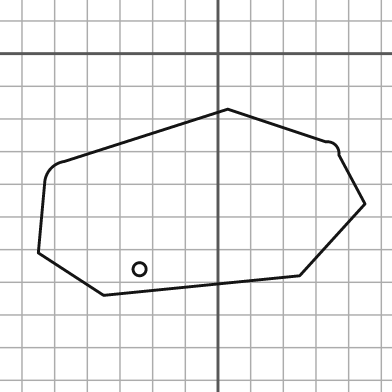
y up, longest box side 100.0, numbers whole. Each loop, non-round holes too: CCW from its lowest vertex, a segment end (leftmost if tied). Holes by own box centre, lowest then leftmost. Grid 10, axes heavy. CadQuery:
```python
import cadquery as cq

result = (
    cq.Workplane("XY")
    .moveTo(-35.0, -74.0)
    .lineTo(25.0, -68.0)
    .lineTo(45.0, -46.0)
    .lineTo(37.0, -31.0)
    .threePointArc((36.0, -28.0), (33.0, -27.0))
    .lineTo(3.0, -17.0)
    .lineTo(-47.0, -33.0)
    .threePointArc((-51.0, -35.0), (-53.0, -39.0))
    .lineTo(-55.0, -61.0)
    .close()
    .moveTo(-24.0, -66.0)
    .circle(2.0)
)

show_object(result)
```